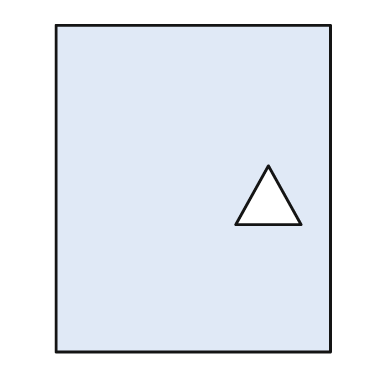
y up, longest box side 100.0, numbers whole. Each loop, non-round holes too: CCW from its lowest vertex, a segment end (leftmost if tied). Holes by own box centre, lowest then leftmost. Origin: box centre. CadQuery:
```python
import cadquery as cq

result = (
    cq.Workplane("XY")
    .moveTo(-42.0, -50.0)
    .lineTo(42.0, -50.0)
    .lineTo(42.0, 50.0)
    .lineTo(-42.0, 50.0)
    .close()
    .moveTo(13.0, -11.0)
    .lineTo(33.0, -11.0)
    .lineTo(23.0, 7.0)
    .close()
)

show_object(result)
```